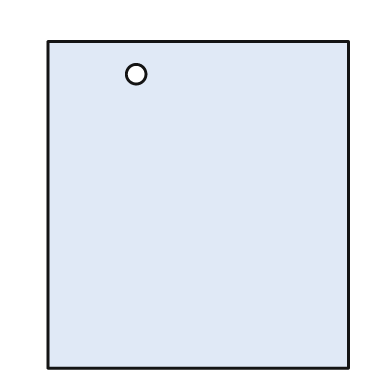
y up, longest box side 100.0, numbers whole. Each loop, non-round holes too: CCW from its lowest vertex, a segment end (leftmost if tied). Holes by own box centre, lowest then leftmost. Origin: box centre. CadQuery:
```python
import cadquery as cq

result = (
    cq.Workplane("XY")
    .moveTo(-46.0, -50.0)
    .lineTo(46.0, -50.0)
    .lineTo(46.0, 50.0)
    .lineTo(-46.0, 50.0)
    .close()
    .moveTo(-19.0, 40.0)
    .circle(3.0)
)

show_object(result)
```